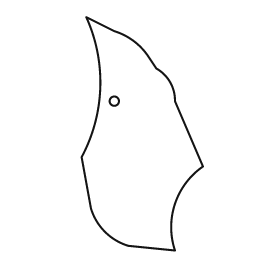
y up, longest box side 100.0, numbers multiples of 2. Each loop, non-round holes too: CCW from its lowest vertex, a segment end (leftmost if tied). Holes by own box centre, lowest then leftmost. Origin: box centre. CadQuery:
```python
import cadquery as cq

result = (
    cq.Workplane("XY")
    .moveTo(14.0, -50.0)
    .threePointArc((14.0, -30.0), (26.0, -14.0))
    .lineTo(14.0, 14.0)
    .threePointArc((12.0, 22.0), (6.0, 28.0))
    .lineTo(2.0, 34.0)
    .threePointArc((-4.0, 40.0), (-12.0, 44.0))
    .lineTo(-24.0, 50.0)
    .threePointArc((-18.0, 20.0), (-26.0, -10.0))
    .lineTo(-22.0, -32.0)
    .threePointArc((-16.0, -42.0), (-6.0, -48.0))
    .close()
    .moveTo(-12.0, 14.0)
    .circle(2.0)
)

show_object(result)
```